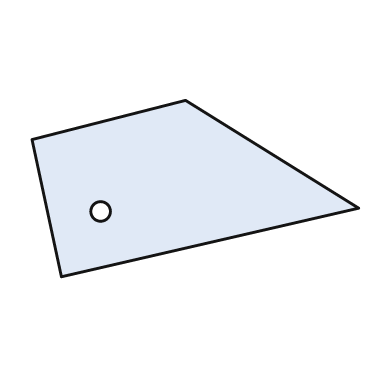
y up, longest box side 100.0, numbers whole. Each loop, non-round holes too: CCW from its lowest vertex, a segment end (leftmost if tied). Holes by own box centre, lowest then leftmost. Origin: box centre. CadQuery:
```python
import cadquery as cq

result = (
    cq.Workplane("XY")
    .moveTo(-41.0, -27.0)
    .lineTo(50.0, -6.0)
    .lineTo(-3.0, 27.0)
    .lineTo(-50.0, 15.0)
    .close()
    .moveTo(-29.0, -7.0)
    .circle(3.0)
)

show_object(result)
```